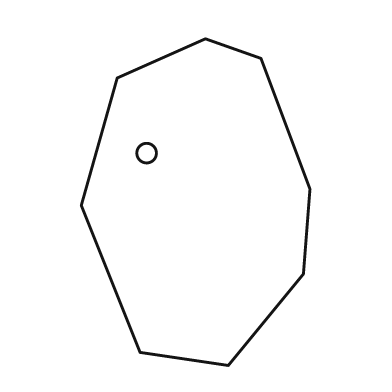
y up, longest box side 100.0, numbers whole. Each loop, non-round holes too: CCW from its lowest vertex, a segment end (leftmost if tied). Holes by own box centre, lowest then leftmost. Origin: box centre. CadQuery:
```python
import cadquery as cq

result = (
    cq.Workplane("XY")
    .moveTo(10.0, -50.0)
    .lineTo(33.0, -22.0)
    .lineTo(35.0, 4.0)
    .lineTo(20.0, 44.0)
    .lineTo(3.0, 50.0)
    .lineTo(-24.0, 38.0)
    .lineTo(-35.0, -1.0)
    .lineTo(-17.0, -46.0)
    .close()
    .moveTo(-15.0, 15.0)
    .circle(3.0)
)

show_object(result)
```